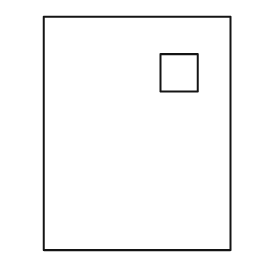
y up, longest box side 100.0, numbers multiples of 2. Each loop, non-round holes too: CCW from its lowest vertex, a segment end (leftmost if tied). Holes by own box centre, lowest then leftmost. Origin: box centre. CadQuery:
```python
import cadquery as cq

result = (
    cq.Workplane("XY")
    .moveTo(-40.0, -50.0)
    .lineTo(40.0, -50.0)
    .lineTo(40.0, 50.0)
    .lineTo(-40.0, 50.0)
    .close()
    .moveTo(10.0, 18.0)
    .lineTo(26.0, 18.0)
    .lineTo(26.0, 34.0)
    .lineTo(10.0, 34.0)
    .close()
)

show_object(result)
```